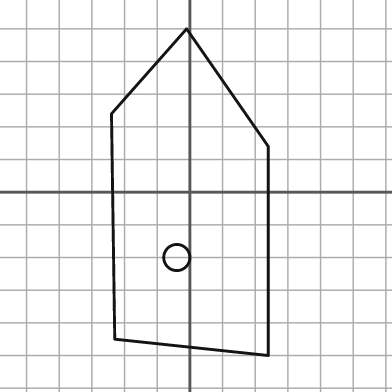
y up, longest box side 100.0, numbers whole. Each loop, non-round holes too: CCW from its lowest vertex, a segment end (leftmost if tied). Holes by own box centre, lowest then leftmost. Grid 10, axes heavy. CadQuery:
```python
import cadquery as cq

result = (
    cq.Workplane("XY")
    .moveTo(24.0, -50.0)
    .lineTo(24.0, 14.0)
    .lineTo(-1.0, 50.0)
    .lineTo(-24.0, 24.0)
    .lineTo(-23.0, -45.0)
    .close()
    .moveTo(-4.0, -20.0)
    .circle(4.0)
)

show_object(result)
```